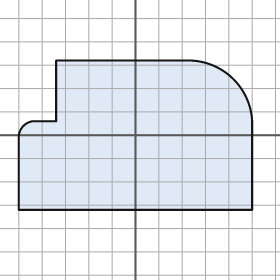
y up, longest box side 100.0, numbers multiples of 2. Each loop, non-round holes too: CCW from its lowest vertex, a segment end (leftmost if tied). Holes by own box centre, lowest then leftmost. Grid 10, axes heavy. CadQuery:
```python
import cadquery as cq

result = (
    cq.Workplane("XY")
    .moveTo(-50.0, -32.0)
    .lineTo(50.0, -32.0)
    .lineTo(50.0, 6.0)
    .threePointArc((42.0, 24.0), (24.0, 32.0))
    .lineTo(-34.0, 32.0)
    .lineTo(-34.0, 6.0)
    .lineTo(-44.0, 6.0)
    .threePointArc((-48.0, 4.0), (-50.0, 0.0))
    .close()
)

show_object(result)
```